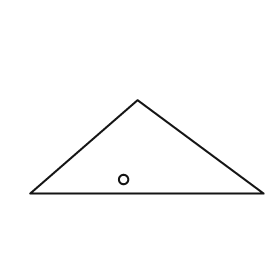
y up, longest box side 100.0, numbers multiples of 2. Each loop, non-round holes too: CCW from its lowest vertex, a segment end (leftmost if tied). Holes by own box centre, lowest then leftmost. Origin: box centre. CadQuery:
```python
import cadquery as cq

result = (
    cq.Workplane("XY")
    .moveTo(-50.0, -20.0)
    .lineTo(50.0, -20.0)
    .lineTo(-4.0, 20.0)
    .close()
    .moveTo(-10.0, -14.0)
    .circle(2.0)
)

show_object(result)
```